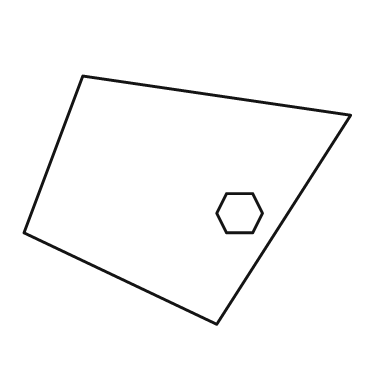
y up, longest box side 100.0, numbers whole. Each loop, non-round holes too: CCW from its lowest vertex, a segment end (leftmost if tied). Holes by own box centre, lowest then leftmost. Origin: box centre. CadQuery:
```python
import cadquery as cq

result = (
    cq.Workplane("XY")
    .moveTo(9.0, -38.0)
    .lineTo(50.0, 26.0)
    .lineTo(-32.0, 38.0)
    .lineTo(-50.0, -10.0)
    .close()
    .moveTo(12.0, -10.0)
    .lineTo(20.0, -10.0)
    .lineTo(23.0, -4.0)
    .lineTo(20.0, 2.0)
    .lineTo(12.0, 2.0)
    .lineTo(9.0, -4.0)
    .close()
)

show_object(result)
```